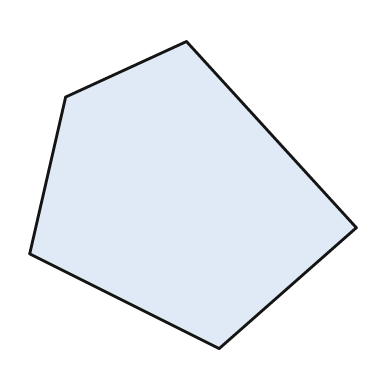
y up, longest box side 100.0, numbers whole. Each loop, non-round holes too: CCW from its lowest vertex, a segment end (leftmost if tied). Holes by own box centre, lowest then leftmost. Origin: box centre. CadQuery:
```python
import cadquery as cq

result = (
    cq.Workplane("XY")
    .moveTo(8.0, -47.0)
    .lineTo(50.0, -10.0)
    .lineTo(-2.0, 47.0)
    .lineTo(-39.0, 30.0)
    .lineTo(-50.0, -18.0)
    .close()
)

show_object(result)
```